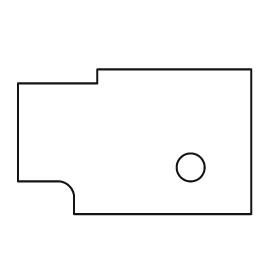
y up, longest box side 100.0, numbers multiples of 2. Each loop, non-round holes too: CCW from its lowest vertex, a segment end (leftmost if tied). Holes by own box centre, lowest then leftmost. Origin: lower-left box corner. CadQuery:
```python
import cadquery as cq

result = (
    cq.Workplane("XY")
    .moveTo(24.0, 0.0)
    .lineTo(100.0, 0.0)
    .lineTo(100.0, 62.0)
    .lineTo(34.0, 62.0)
    .lineTo(34.0, 56.0)
    .lineTo(0.0, 56.0)
    .lineTo(0.0, 14.0)
    .lineTo(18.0, 14.0)
    .threePointArc((22.0, 12.0), (24.0, 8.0))
    .close()
    .moveTo(74.0, 20.0)
    .circle(6.0)
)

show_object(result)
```